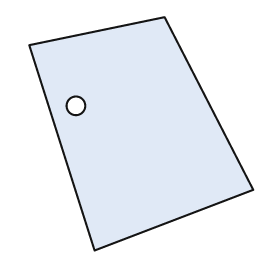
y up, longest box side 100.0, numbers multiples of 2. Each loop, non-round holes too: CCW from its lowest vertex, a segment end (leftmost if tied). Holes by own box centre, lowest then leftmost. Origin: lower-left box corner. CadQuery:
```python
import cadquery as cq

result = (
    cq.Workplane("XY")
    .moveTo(28.0, 0.0)
    .lineTo(96.0, 26.0)
    .lineTo(58.0, 100.0)
    .lineTo(0.0, 88.0)
    .close()
    .moveTo(20.0, 62.0)
    .circle(4.0)
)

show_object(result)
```